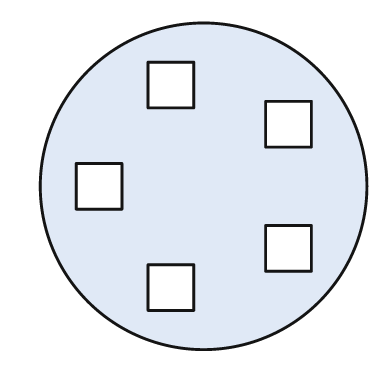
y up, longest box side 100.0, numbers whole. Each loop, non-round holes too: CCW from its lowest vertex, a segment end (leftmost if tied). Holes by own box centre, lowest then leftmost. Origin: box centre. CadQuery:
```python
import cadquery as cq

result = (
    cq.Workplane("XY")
    .moveTo(0.0, 0.0)
    .circle(50.0)
    .moveTo(-17.0, -38.0)
    .lineTo(-3.0, -38.0)
    .lineTo(-3.0, -24.0)
    .lineTo(-17.0, -24.0)
    .close()
    .moveTo(19.0, -26.0)
    .lineTo(33.0, -26.0)
    .lineTo(33.0, -12.0)
    .lineTo(19.0, -12.0)
    .close()
    .moveTo(-39.0, -7.0)
    .lineTo(-25.0, -7.0)
    .lineTo(-25.0, 7.0)
    .lineTo(-39.0, 7.0)
    .close()
    .moveTo(19.0, 12.0)
    .lineTo(33.0, 12.0)
    .lineTo(33.0, 26.0)
    .lineTo(19.0, 26.0)
    .close()
    .moveTo(-17.0, 24.0)
    .lineTo(-3.0, 24.0)
    .lineTo(-3.0, 38.0)
    .lineTo(-17.0, 38.0)
    .close()
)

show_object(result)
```